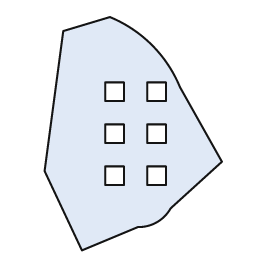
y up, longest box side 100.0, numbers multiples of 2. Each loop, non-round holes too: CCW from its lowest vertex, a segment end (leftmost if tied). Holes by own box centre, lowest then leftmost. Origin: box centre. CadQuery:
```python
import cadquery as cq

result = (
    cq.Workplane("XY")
    .moveTo(-22.0, -50.0)
    .lineTo(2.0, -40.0)
    .threePointArc((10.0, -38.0), (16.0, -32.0))
    .lineTo(38.0, -12.0)
    .lineTo(20.0, 20.0)
    .threePointArc((8.0, 38.0), (-10.0, 50.0))
    .lineTo(-30.0, 44.0)
    .lineTo(-38.0, -16.0)
    .close()
    .moveTo(-12.0, -22.0)
    .lineTo(-4.0, -22.0)
    .lineTo(-4.0, -14.0)
    .lineTo(-12.0, -14.0)
    .close()
    .moveTo(6.0, -22.0)
    .lineTo(14.0, -22.0)
    .lineTo(14.0, -14.0)
    .lineTo(6.0, -14.0)
    .close()
    .moveTo(-12.0, -4.0)
    .lineTo(-4.0, -4.0)
    .lineTo(-4.0, 4.0)
    .lineTo(-12.0, 4.0)
    .close()
    .moveTo(6.0, -4.0)
    .lineTo(14.0, -4.0)
    .lineTo(14.0, 4.0)
    .lineTo(6.0, 4.0)
    .close()
    .moveTo(-12.0, 14.0)
    .lineTo(-4.0, 14.0)
    .lineTo(-4.0, 22.0)
    .lineTo(-12.0, 22.0)
    .close()
    .moveTo(6.0, 14.0)
    .lineTo(14.0, 14.0)
    .lineTo(14.0, 22.0)
    .lineTo(6.0, 22.0)
    .close()
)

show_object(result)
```